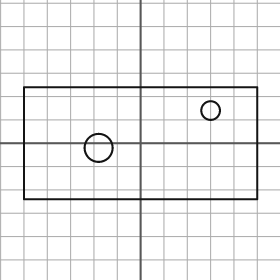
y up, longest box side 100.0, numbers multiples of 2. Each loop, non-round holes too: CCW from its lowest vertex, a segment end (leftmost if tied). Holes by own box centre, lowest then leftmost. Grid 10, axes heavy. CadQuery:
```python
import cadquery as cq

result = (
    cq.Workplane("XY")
    .moveTo(-50.0, -24.0)
    .lineTo(50.0, -24.0)
    .lineTo(50.0, 24.0)
    .lineTo(-50.0, 24.0)
    .close()
    .moveTo(-18.0, -2.0)
    .circle(6.0)
    .moveTo(30.0, 14.0)
    .circle(4.0)
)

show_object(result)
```